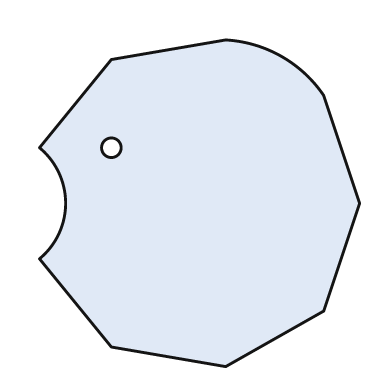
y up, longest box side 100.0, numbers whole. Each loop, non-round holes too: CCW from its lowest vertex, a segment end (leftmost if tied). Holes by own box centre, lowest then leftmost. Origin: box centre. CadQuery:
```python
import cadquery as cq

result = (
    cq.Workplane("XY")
    .moveTo(8.0, -50.0)
    .lineTo(38.0, -33.0)
    .lineTo(49.0, 0.0)
    .lineTo(38.0, 33.0)
    .threePointArc((25.0, 45.0), (8.0, 50.0))
    .lineTo(-27.0, 44.0)
    .lineTo(-49.0, 17.0)
    .threePointArc((-41.0, 0.0), (-49.0, -17.0))
    .lineTo(-27.0, -44.0)
    .close()
    .moveTo(-27.0, 17.0)
    .circle(3.0)
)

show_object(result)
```